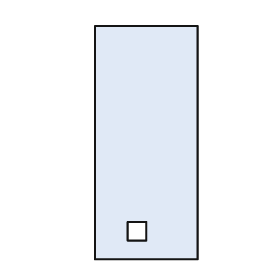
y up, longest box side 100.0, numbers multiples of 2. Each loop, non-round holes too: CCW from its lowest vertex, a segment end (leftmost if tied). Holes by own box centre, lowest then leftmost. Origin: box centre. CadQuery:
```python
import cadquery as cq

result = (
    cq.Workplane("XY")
    .moveTo(-22.0, -50.0)
    .lineTo(22.0, -50.0)
    .lineTo(22.0, 50.0)
    .lineTo(-22.0, 50.0)
    .close()
    .moveTo(-8.0, -42.0)
    .lineTo(0.0, -42.0)
    .lineTo(0.0, -34.0)
    .lineTo(-8.0, -34.0)
    .close()
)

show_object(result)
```